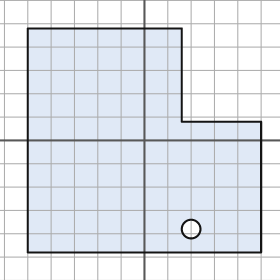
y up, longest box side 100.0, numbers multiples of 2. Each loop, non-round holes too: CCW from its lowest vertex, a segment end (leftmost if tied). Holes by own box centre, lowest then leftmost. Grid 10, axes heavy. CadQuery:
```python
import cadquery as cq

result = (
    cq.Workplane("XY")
    .moveTo(-50.0, -48.0)
    .lineTo(50.0, -48.0)
    .lineTo(50.0, 8.0)
    .lineTo(16.0, 8.0)
    .lineTo(16.0, 48.0)
    .lineTo(-50.0, 48.0)
    .close()
    .moveTo(20.0, -38.0)
    .circle(4.0)
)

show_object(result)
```